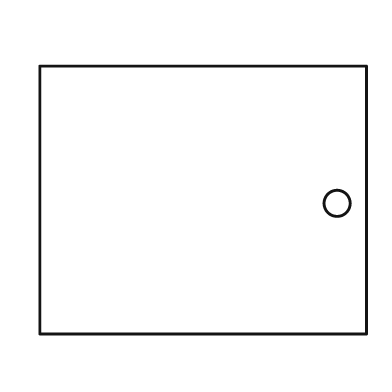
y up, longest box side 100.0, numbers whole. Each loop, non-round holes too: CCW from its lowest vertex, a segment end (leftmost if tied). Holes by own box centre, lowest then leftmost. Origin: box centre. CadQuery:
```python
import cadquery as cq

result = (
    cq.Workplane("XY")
    .moveTo(-50.0, -41.0)
    .lineTo(50.0, -41.0)
    .lineTo(50.0, 41.0)
    .lineTo(-50.0, 41.0)
    .close()
    .moveTo(41.0, -1.0)
    .circle(4.0)
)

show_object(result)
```